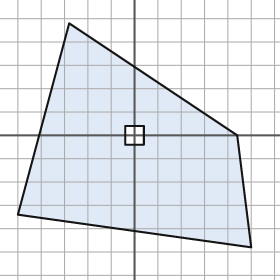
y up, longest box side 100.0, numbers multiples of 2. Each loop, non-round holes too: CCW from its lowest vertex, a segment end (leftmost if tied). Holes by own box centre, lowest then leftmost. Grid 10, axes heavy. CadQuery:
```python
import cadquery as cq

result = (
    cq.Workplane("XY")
    .moveTo(50.0, -48.0)
    .lineTo(44.0, 0.0)
    .lineTo(-28.0, 48.0)
    .lineTo(-50.0, -34.0)
    .close()
    .moveTo(-4.0, -4.0)
    .lineTo(4.0, -4.0)
    .lineTo(4.0, 4.0)
    .lineTo(-4.0, 4.0)
    .close()
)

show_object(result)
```